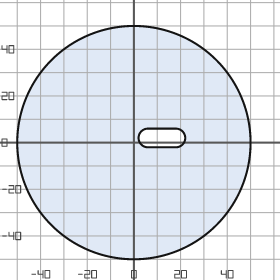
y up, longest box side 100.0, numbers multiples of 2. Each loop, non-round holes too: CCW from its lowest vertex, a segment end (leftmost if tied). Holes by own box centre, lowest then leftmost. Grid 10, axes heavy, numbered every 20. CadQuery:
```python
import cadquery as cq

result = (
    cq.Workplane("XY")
    .moveTo(0.0, 0.0)
    .circle(50.0)
    .moveTo(6.0, -2.0)
    .lineTo(18.0, -2.0)
    .threePointArc((22.0, 2.0), (18.0, 6.0))
    .lineTo(6.0, 6.0)
    .threePointArc((2.0, 2.0), (6.0, -2.0))
    .close()
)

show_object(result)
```